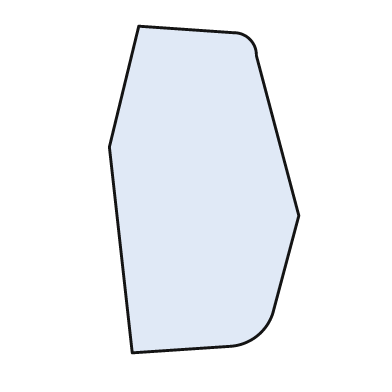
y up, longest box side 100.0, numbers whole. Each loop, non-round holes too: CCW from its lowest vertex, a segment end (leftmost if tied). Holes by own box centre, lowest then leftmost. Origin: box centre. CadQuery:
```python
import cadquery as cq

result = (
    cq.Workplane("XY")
    .moveTo(-22.0, -50.0)
    .lineTo(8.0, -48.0)
    .threePointArc((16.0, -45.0), (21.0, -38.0))
    .lineTo(29.0, -8.0)
    .lineTo(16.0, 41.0)
    .threePointArc((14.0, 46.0), (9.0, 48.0))
    .lineTo(-20.0, 50.0)
    .lineTo(-29.0, 13.0)
    .close()
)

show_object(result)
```